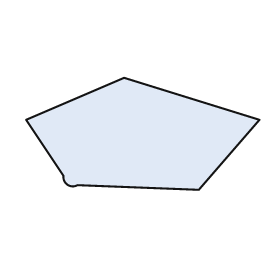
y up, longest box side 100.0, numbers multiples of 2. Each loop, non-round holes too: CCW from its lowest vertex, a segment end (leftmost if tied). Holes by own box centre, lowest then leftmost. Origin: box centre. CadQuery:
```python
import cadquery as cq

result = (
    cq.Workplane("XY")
    .moveTo(24.0, -24.0)
    .lineTo(50.0, 6.0)
    .lineTo(-8.0, 24.0)
    .lineTo(-50.0, 6.0)
    .lineTo(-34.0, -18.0)
    .threePointArc((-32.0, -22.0), (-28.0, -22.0))
    .close()
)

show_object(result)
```